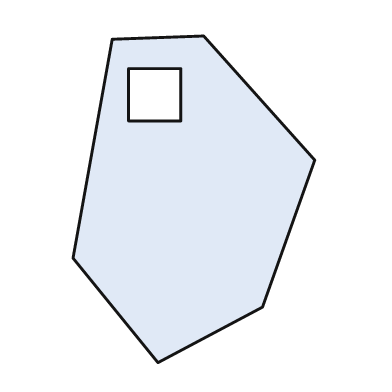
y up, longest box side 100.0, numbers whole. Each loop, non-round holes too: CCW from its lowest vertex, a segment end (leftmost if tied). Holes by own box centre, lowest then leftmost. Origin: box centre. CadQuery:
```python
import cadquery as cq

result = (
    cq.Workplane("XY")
    .moveTo(-11.0, -50.0)
    .lineTo(21.0, -33.0)
    .lineTo(37.0, 12.0)
    .lineTo(3.0, 50.0)
    .lineTo(-25.0, 49.0)
    .lineTo(-37.0, -18.0)
    .close()
    .moveTo(-20.0, 24.0)
    .lineTo(-4.0, 24.0)
    .lineTo(-4.0, 40.0)
    .lineTo(-20.0, 40.0)
    .close()
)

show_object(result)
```